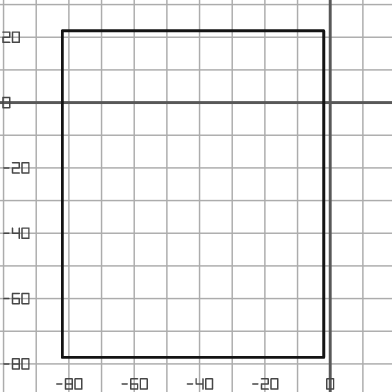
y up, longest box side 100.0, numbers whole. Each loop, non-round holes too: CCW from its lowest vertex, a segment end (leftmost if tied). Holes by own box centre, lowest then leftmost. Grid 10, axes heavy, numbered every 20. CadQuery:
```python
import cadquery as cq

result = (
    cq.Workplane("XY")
    .moveTo(-82.0, -78.0)
    .lineTo(-2.0, -78.0)
    .lineTo(-2.0, 22.0)
    .lineTo(-82.0, 22.0)
    .close()
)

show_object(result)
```